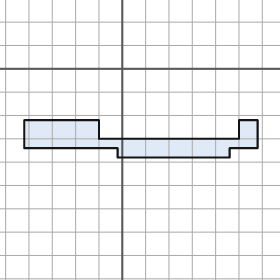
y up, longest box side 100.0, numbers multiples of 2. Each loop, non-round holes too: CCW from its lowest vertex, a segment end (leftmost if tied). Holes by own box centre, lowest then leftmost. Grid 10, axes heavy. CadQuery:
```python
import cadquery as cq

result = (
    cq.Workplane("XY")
    .moveTo(-2.0, -38.0)
    .lineTo(46.0, -38.0)
    .lineTo(46.0, -34.0)
    .lineTo(58.0, -34.0)
    .lineTo(58.0, -22.0)
    .lineTo(50.0, -22.0)
    .lineTo(50.0, -30.0)
    .lineTo(-10.0, -30.0)
    .lineTo(-10.0, -22.0)
    .lineTo(-42.0, -22.0)
    .lineTo(-42.0, -34.0)
    .lineTo(-2.0, -34.0)
    .close()
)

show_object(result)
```